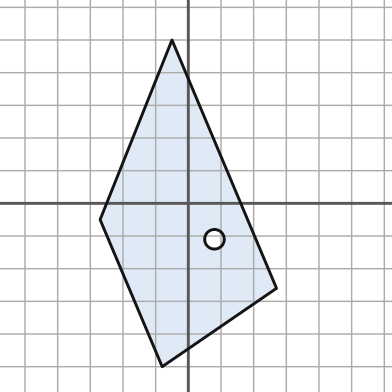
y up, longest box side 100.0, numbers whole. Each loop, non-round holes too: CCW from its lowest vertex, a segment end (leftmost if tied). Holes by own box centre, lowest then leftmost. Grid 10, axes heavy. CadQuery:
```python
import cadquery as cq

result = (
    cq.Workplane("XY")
    .moveTo(-8.0, -50.0)
    .lineTo(27.0, -26.0)
    .lineTo(-5.0, 50.0)
    .lineTo(-27.0, -5.0)
    .close()
    .moveTo(8.0, -11.0)
    .circle(3.0)
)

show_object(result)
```